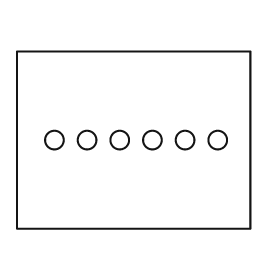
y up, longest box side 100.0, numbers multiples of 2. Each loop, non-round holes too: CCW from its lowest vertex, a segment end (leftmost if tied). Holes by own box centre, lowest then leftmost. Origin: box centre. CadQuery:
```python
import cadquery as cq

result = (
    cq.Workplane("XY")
    .moveTo(-50.0, -38.0)
    .lineTo(50.0, -38.0)
    .lineTo(50.0, 38.0)
    .lineTo(-50.0, 38.0)
    .close()
    .moveTo(-34.0, 0.0)
    .circle(4.0)
    .moveTo(-20.0, 0.0)
    .circle(4.0)
    .moveTo(-6.0, 0.0)
    .circle(4.0)
    .moveTo(8.0, 0.0)
    .circle(4.0)
    .moveTo(22.0, 0.0)
    .circle(4.0)
    .moveTo(36.0, 0.0)
    .circle(4.0)
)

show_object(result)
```